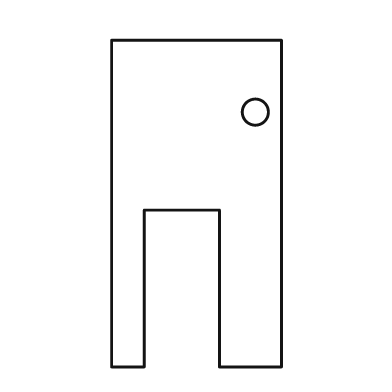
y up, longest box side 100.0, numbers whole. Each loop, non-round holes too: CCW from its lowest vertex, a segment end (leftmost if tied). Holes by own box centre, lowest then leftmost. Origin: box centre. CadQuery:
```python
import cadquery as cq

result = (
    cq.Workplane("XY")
    .moveTo(-26.0, -50.0)
    .lineTo(-16.0, -50.0)
    .lineTo(-16.0, -2.0)
    .lineTo(7.0, -2.0)
    .lineTo(7.0, -50.0)
    .lineTo(26.0, -50.0)
    .lineTo(26.0, 50.0)
    .lineTo(-26.0, 50.0)
    .close()
    .moveTo(18.0, 28.0)
    .circle(4.0)
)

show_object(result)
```